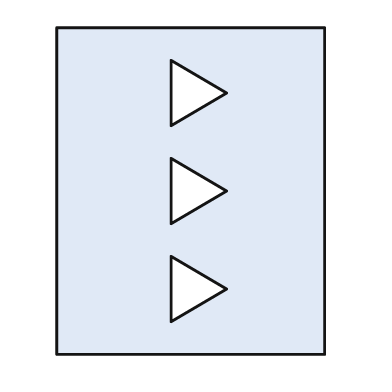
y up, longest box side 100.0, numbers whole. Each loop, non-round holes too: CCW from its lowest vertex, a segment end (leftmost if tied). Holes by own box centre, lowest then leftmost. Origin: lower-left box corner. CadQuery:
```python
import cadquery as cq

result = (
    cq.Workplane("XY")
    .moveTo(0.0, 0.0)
    .lineTo(82.0, 0.0)
    .lineTo(82.0, 100.0)
    .lineTo(0.0, 100.0)
    .close()
    .moveTo(35.0, 10.0)
    .lineTo(52.0, 20.0)
    .lineTo(35.0, 30.0)
    .close()
    .moveTo(35.0, 40.0)
    .lineTo(52.0, 50.0)
    .lineTo(35.0, 60.0)
    .close()
    .moveTo(35.0, 70.0)
    .lineTo(52.0, 80.0)
    .lineTo(35.0, 90.0)
    .close()
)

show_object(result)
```